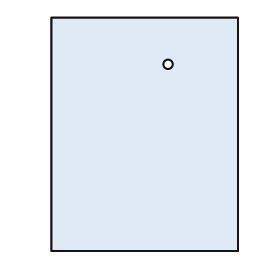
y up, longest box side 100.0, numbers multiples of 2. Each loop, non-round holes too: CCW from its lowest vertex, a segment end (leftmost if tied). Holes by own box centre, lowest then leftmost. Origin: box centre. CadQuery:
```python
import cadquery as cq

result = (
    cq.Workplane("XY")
    .moveTo(-40.0, -50.0)
    .lineTo(40.0, -50.0)
    .lineTo(40.0, 50.0)
    .lineTo(-40.0, 50.0)
    .close()
    .moveTo(10.0, 30.0)
    .circle(2.0)
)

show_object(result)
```